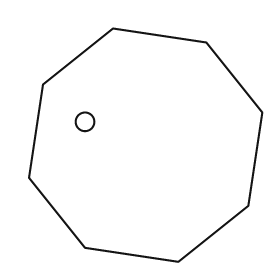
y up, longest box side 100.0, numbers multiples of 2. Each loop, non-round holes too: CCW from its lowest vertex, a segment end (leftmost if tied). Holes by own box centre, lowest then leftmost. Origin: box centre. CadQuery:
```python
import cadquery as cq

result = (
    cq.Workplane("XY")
    .moveTo(14.0, -50.0)
    .lineTo(44.0, -26.0)
    .lineTo(50.0, 14.0)
    .lineTo(26.0, 44.0)
    .lineTo(-14.0, 50.0)
    .lineTo(-44.0, 26.0)
    .lineTo(-50.0, -14.0)
    .lineTo(-26.0, -44.0)
    .close()
    .moveTo(-26.0, 10.0)
    .circle(4.0)
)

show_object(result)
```